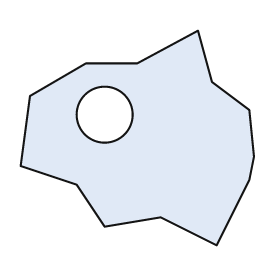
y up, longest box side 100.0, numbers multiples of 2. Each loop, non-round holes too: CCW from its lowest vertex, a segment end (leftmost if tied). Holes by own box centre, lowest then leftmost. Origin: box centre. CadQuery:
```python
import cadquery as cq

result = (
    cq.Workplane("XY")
    .moveTo(34.0, -46.0)
    .lineTo(48.0, -18.0)
    .lineTo(50.0, -8.0)
    .lineTo(48.0, 12.0)
    .lineTo(32.0, 24.0)
    .lineTo(26.0, 46.0)
    .lineTo(0.0, 32.0)
    .lineTo(-22.0, 32.0)
    .lineTo(-46.0, 18.0)
    .lineTo(-50.0, -12.0)
    .lineTo(-26.0, -20.0)
    .lineTo(-14.0, -38.0)
    .lineTo(10.0, -34.0)
    .close()
    .moveTo(-14.0, 10.0)
    .circle(12.0)
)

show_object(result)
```